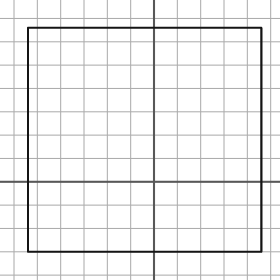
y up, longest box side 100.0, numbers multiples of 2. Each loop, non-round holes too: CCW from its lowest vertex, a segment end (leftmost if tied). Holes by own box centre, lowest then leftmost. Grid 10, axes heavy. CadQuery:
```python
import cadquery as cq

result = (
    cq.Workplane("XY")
    .moveTo(-54.0, -30.0)
    .lineTo(46.0, -30.0)
    .lineTo(46.0, 66.0)
    .lineTo(-54.0, 66.0)
    .close()
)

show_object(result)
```